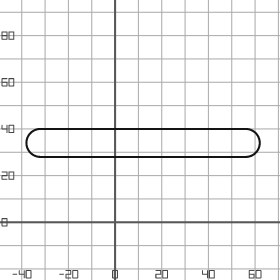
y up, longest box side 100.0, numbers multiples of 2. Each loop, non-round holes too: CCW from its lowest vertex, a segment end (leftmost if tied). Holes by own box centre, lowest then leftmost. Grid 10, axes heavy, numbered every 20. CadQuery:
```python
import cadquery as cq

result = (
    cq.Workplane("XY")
    .moveTo(-32.0, 28.0)
    .lineTo(56.0, 28.0)
    .threePointArc((62.0, 34.0), (56.0, 40.0))
    .lineTo(-32.0, 40.0)
    .threePointArc((-38.0, 34.0), (-32.0, 28.0))
    .close()
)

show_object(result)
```